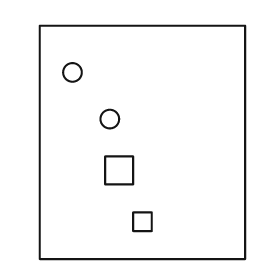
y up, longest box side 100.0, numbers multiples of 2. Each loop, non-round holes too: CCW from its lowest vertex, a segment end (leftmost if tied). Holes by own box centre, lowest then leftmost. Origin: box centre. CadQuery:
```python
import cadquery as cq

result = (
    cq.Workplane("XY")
    .moveTo(-44.0, -50.0)
    .lineTo(44.0, -50.0)
    .lineTo(44.0, 50.0)
    .lineTo(-44.0, 50.0)
    .close()
    .moveTo(-4.0, -38.0)
    .lineTo(4.0, -38.0)
    .lineTo(4.0, -30.0)
    .lineTo(-4.0, -30.0)
    .close()
    .moveTo(-16.0, -18.0)
    .lineTo(-4.0, -18.0)
    .lineTo(-4.0, -6.0)
    .lineTo(-16.0, -6.0)
    .close()
    .moveTo(-14.0, 10.0)
    .circle(4.0)
    .moveTo(-30.0, 30.0)
    .circle(4.0)
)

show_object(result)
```